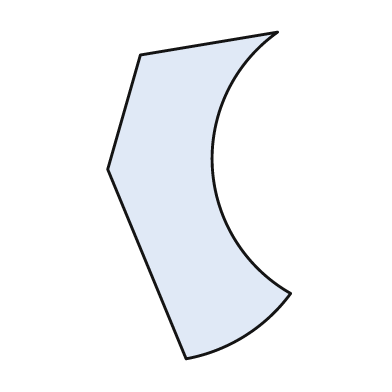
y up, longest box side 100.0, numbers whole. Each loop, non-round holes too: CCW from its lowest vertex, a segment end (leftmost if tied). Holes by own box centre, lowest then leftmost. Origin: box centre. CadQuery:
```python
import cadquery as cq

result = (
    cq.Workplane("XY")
    .moveTo(-4.0, -50.0)
    .threePointArc((14.0, -43.0), (28.0, -30.0))
    .threePointArc((4.0, 9.0), (24.0, 50.0))
    .lineTo(-18.0, 43.0)
    .lineTo(-28.0, 8.0)
    .close()
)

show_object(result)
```